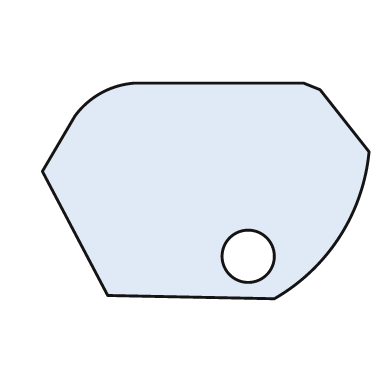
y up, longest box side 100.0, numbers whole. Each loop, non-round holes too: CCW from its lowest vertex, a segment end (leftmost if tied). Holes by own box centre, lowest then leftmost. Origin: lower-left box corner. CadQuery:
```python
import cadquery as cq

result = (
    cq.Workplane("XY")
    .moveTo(71.0, 0.0)
    .threePointArc((91.0, 19.0), (100.0, 45.0))
    .lineTo(85.0, 64.0)
    .lineTo(80.0, 66.0)
    .lineTo(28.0, 66.0)
    .threePointArc((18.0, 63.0), (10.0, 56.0))
    .lineTo(0.0, 39.0)
    .lineTo(20.0, 1.0)
    .close()
    .moveTo(63.0, 13.0)
    .circle(8.0)
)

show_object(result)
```